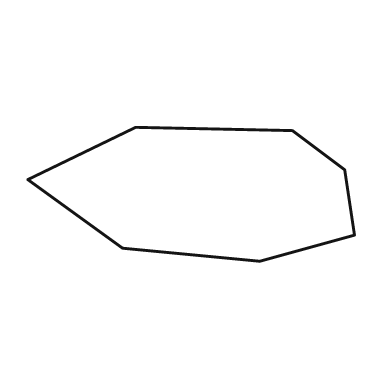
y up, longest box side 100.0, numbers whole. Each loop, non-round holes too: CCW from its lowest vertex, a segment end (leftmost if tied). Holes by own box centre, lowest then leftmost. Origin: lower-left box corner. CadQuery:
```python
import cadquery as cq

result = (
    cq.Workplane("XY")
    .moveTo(71.0, 0.0)
    .lineTo(100.0, 8.0)
    .lineTo(97.0, 28.0)
    .lineTo(81.0, 40.0)
    .lineTo(33.0, 41.0)
    .lineTo(0.0, 25.0)
    .lineTo(29.0, 4.0)
    .close()
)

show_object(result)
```